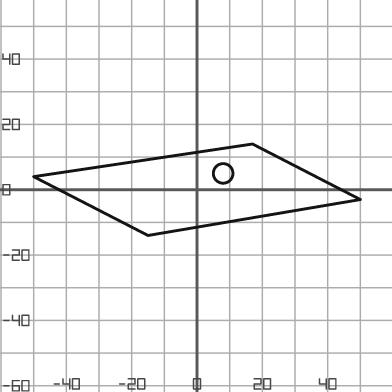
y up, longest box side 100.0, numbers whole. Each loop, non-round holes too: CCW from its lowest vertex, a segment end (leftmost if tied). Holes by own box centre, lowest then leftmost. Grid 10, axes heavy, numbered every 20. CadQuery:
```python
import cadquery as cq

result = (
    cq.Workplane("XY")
    .moveTo(-15.0, -14.0)
    .lineTo(50.0, -3.0)
    .lineTo(17.0, 14.0)
    .lineTo(-50.0, 4.0)
    .close()
    .moveTo(8.0, 5.0)
    .circle(3.0)
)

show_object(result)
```